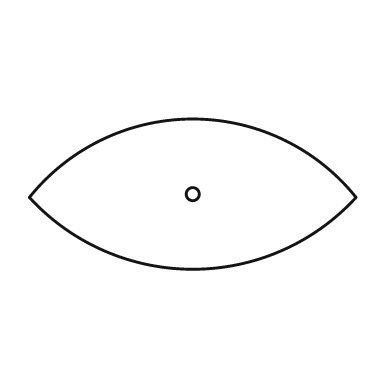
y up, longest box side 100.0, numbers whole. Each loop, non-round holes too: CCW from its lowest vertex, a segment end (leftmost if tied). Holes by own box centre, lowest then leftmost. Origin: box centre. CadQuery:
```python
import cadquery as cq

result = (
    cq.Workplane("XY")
    .moveTo(-50.0, -1.0)
    .threePointArc((0.0, -23.0), (50.0, -1.0))
    .threePointArc((0.0, 23.0), (-50.0, -1.0))
    .close()
    .moveTo(0.0, 0.0)
    .circle(2.0)
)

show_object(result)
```